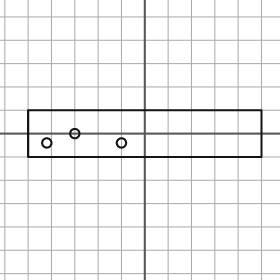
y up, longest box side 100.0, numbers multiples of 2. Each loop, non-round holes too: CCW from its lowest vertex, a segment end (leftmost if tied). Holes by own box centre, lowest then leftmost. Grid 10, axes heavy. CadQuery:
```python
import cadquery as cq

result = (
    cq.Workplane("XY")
    .moveTo(-50.0, -10.0)
    .lineTo(50.0, -10.0)
    .lineTo(50.0, 10.0)
    .lineTo(-50.0, 10.0)
    .close()
    .moveTo(-42.0, -4.0)
    .circle(2.0)
    .moveTo(-10.0, -4.0)
    .circle(2.0)
    .moveTo(-30.0, 0.0)
    .circle(2.0)
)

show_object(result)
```